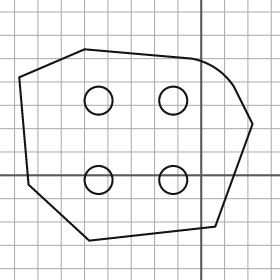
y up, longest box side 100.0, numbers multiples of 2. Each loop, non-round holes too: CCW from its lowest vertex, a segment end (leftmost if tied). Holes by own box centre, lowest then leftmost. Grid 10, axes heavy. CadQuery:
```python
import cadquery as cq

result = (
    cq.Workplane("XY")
    .moveTo(-48.0, -28.0)
    .lineTo(6.0, -22.0)
    .lineTo(22.0, 22.0)
    .lineTo(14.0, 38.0)
    .threePointArc((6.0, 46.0), (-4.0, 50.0))
    .lineTo(-50.0, 54.0)
    .lineTo(-78.0, 42.0)
    .lineTo(-74.0, -4.0)
    .close()
    .moveTo(-44.0, -2.0)
    .circle(6.0)
    .moveTo(-12.0, -2.0)
    .circle(6.0)
    .moveTo(-44.0, 32.0)
    .circle(6.0)
    .moveTo(-12.0, 32.0)
    .circle(6.0)
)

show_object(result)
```